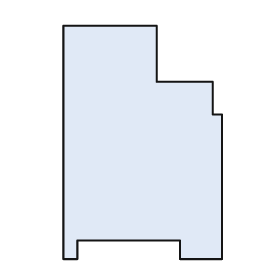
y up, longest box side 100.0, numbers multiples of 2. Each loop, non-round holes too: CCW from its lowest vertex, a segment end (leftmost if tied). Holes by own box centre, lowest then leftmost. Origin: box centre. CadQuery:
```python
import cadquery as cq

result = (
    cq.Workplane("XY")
    .moveTo(-34.0, -50.0)
    .lineTo(-28.0, -50.0)
    .lineTo(-28.0, -42.0)
    .lineTo(16.0, -42.0)
    .lineTo(16.0, -50.0)
    .lineTo(34.0, -50.0)
    .lineTo(34.0, 12.0)
    .lineTo(30.0, 12.0)
    .lineTo(30.0, 26.0)
    .lineTo(6.0, 26.0)
    .lineTo(6.0, 50.0)
    .lineTo(-34.0, 50.0)
    .close()
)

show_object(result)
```